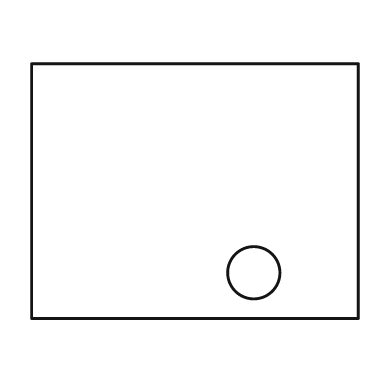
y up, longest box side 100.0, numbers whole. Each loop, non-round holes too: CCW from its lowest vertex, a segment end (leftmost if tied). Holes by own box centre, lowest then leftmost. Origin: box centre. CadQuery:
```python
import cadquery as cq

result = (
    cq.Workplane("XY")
    .moveTo(-50.0, -39.0)
    .lineTo(50.0, -39.0)
    .lineTo(50.0, 39.0)
    .lineTo(-50.0, 39.0)
    .close()
    .moveTo(18.0, -25.0)
    .circle(8.0)
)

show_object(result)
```